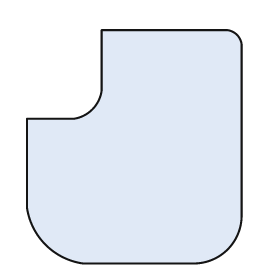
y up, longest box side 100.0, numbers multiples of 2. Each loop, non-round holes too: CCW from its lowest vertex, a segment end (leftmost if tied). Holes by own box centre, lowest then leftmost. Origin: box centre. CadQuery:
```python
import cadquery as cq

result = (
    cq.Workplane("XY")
    .moveTo(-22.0, -50.0)
    .lineTo(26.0, -50.0)
    .threePointArc((40.0, -44.0), (46.0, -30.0))
    .lineTo(46.0, 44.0)
    .threePointArc((44.0, 48.0), (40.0, 50.0))
    .lineTo(-14.0, 50.0)
    .lineTo(-14.0, 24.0)
    .threePointArc((-18.0, 16.0), (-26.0, 12.0))
    .lineTo(-46.0, 12.0)
    .lineTo(-46.0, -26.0)
    .threePointArc((-38.0, -42.0), (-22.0, -50.0))
    .close()
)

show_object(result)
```